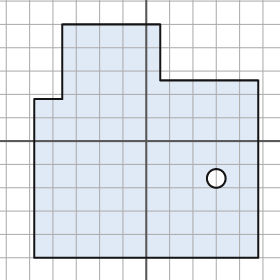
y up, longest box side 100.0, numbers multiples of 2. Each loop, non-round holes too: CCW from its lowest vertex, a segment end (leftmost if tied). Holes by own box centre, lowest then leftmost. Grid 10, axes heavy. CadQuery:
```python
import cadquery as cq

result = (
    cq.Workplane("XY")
    .moveTo(-48.0, -50.0)
    .lineTo(48.0, -50.0)
    .lineTo(48.0, 26.0)
    .lineTo(6.0, 26.0)
    .lineTo(6.0, 50.0)
    .lineTo(-36.0, 50.0)
    .lineTo(-36.0, 18.0)
    .lineTo(-48.0, 18.0)
    .close()
    .moveTo(30.0, -16.0)
    .circle(4.0)
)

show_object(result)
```